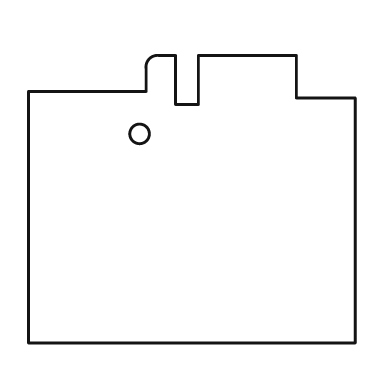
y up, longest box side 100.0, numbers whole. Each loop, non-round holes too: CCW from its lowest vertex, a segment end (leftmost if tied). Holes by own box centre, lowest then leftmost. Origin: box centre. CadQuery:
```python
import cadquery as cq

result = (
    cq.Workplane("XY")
    .moveTo(-50.0, -44.0)
    .lineTo(50.0, -44.0)
    .lineTo(50.0, 31.0)
    .lineTo(32.0, 31.0)
    .lineTo(32.0, 44.0)
    .lineTo(2.0, 44.0)
    .lineTo(2.0, 29.0)
    .lineTo(-5.0, 29.0)
    .lineTo(-5.0, 44.0)
    .lineTo(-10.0, 44.0)
    .threePointArc((-13.0, 43.0), (-14.0, 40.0))
    .lineTo(-14.0, 33.0)
    .lineTo(-50.0, 33.0)
    .close()
    .moveTo(-16.0, 20.0)
    .circle(3.0)
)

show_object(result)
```